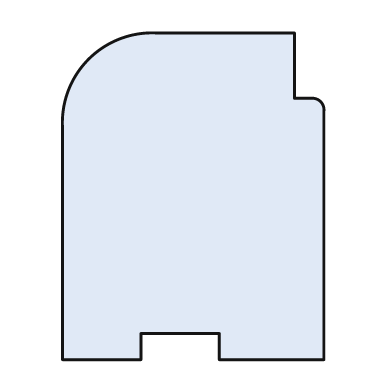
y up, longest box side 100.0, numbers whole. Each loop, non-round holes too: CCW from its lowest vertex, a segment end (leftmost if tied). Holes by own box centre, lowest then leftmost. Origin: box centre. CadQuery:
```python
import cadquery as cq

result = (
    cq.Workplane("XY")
    .moveTo(-40.0, -50.0)
    .lineTo(-16.0, -50.0)
    .lineTo(-16.0, -42.0)
    .lineTo(8.0, -42.0)
    .lineTo(8.0, -50.0)
    .lineTo(40.0, -50.0)
    .lineTo(40.0, 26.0)
    .threePointArc((39.0, 29.0), (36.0, 30.0))
    .lineTo(31.0, 30.0)
    .lineTo(31.0, 50.0)
    .lineTo(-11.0, 50.0)
    .threePointArc((-32.0, 42.0), (-40.0, 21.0))
    .close()
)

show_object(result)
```